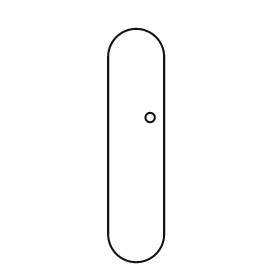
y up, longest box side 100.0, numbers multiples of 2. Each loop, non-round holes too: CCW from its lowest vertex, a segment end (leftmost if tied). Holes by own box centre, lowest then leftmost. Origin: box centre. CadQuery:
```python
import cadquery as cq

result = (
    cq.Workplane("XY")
    .moveTo(-12.0, -38.0)
    .threePointArc((0.0, -50.0), (12.0, -38.0))
    .lineTo(12.0, 38.0)
    .threePointArc((0.0, 50.0), (-12.0, 38.0))
    .close()
    .moveTo(6.0, 12.0)
    .circle(2.0)
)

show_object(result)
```